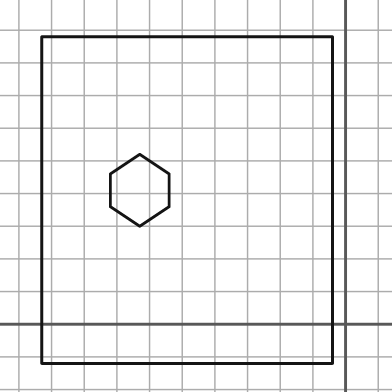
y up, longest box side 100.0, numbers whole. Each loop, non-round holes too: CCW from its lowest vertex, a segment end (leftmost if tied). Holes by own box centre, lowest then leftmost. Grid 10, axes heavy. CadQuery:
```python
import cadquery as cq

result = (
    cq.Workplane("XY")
    .moveTo(-93.0, -12.0)
    .lineTo(-4.0, -12.0)
    .lineTo(-4.0, 88.0)
    .lineTo(-93.0, 88.0)
    .close()
    .moveTo(-63.0, 30.0)
    .lineTo(-54.0, 36.0)
    .lineTo(-54.0, 46.0)
    .lineTo(-63.0, 52.0)
    .lineTo(-72.0, 46.0)
    .lineTo(-72.0, 36.0)
    .close()
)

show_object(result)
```